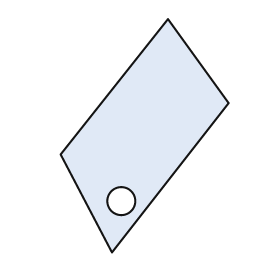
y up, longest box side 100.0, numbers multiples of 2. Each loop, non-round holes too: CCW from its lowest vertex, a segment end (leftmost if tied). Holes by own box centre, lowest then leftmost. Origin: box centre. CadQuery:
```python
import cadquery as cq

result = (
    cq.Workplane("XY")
    .moveTo(-14.0, -50.0)
    .lineTo(36.0, 14.0)
    .lineTo(10.0, 50.0)
    .lineTo(-36.0, -8.0)
    .close()
    .moveTo(-10.0, -28.0)
    .circle(6.0)
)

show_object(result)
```